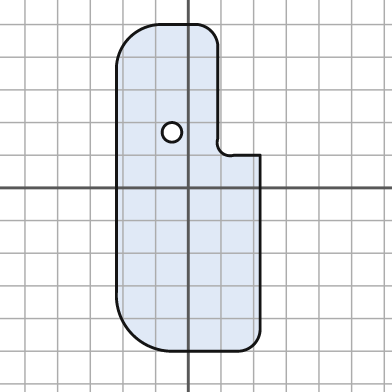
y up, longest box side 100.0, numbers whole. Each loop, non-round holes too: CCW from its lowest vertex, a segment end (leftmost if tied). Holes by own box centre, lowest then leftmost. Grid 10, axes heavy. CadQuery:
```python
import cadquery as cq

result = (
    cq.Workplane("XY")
    .moveTo(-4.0, -50.0)
    .lineTo(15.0, -50.0)
    .threePointArc((20.0, -48.0), (22.0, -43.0))
    .lineTo(22.0, 10.0)
    .lineTo(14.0, 10.0)
    .threePointArc((10.0, 11.0), (9.0, 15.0))
    .lineTo(9.0, 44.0)
    .threePointArc((7.0, 48.0), (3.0, 50.0))
    .lineTo(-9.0, 50.0)
    .threePointArc((-18.0, 46.0), (-22.0, 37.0))
    .lineTo(-22.0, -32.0)
    .threePointArc((-17.0, -45.0), (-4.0, -50.0))
    .close()
    .moveTo(-5.0, 17.0)
    .circle(3.0)
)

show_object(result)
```